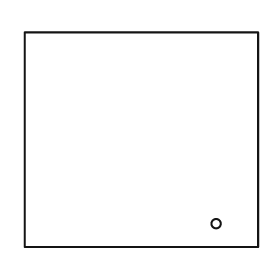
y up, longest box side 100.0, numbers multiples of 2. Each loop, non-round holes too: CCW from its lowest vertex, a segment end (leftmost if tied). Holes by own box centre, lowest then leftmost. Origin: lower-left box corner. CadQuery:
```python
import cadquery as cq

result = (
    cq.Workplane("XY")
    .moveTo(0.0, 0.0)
    .lineTo(100.0, 0.0)
    .lineTo(100.0, 92.0)
    .lineTo(0.0, 92.0)
    .close()
    .moveTo(82.0, 10.0)
    .circle(2.0)
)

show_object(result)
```